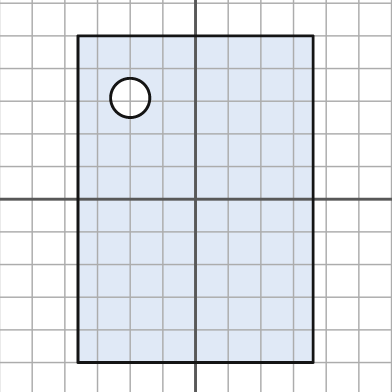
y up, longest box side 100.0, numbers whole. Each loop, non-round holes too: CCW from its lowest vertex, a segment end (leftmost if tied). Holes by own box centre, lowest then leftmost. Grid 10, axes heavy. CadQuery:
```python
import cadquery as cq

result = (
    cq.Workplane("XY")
    .moveTo(-36.0, -50.0)
    .lineTo(36.0, -50.0)
    .lineTo(36.0, 50.0)
    .lineTo(-36.0, 50.0)
    .close()
    .moveTo(-20.0, 31.0)
    .circle(6.0)
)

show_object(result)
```